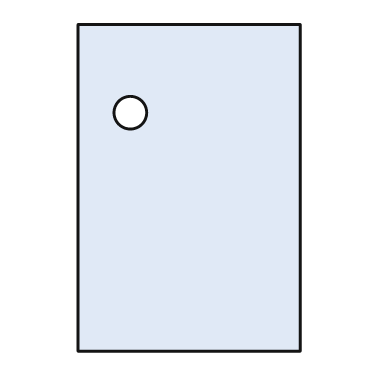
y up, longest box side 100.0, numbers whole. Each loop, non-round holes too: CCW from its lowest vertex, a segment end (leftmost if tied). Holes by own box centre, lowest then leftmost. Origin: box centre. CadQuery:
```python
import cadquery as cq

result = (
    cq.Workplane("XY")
    .moveTo(-34.0, -50.0)
    .lineTo(34.0, -50.0)
    .lineTo(34.0, 50.0)
    .lineTo(-34.0, 50.0)
    .close()
    .moveTo(-18.0, 23.0)
    .circle(5.0)
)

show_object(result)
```